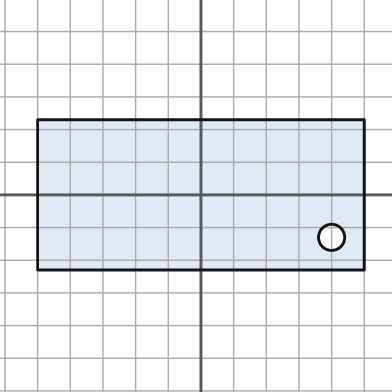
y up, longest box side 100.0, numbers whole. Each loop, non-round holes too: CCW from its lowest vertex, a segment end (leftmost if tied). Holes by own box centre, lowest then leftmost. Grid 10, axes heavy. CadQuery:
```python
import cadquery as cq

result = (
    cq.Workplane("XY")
    .moveTo(-50.0, -23.0)
    .lineTo(50.0, -23.0)
    .lineTo(50.0, 23.0)
    .lineTo(-50.0, 23.0)
    .close()
    .moveTo(40.0, -13.0)
    .circle(4.0)
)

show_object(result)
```